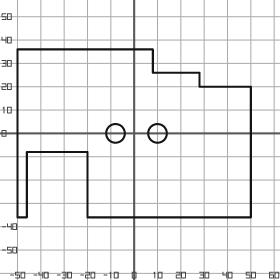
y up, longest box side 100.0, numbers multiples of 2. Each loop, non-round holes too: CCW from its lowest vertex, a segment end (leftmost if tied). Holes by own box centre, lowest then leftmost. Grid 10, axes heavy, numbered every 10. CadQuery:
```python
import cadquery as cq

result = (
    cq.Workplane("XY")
    .moveTo(-50.0, -36.0)
    .lineTo(-46.0, -36.0)
    .lineTo(-46.0, -8.0)
    .lineTo(-20.0, -8.0)
    .lineTo(-20.0, -36.0)
    .lineTo(50.0, -36.0)
    .lineTo(50.0, 20.0)
    .lineTo(28.0, 20.0)
    .lineTo(28.0, 26.0)
    .lineTo(8.0, 26.0)
    .lineTo(8.0, 36.0)
    .lineTo(-50.0, 36.0)
    .close()
    .moveTo(-8.0, 0.0)
    .circle(4.0)
    .moveTo(10.0, 0.0)
    .circle(4.0)
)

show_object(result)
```